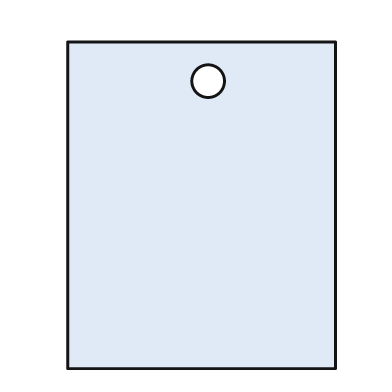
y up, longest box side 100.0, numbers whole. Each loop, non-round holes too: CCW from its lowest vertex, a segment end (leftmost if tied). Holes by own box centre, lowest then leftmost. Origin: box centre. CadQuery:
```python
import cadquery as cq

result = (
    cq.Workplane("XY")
    .moveTo(-41.0, -50.0)
    .lineTo(41.0, -50.0)
    .lineTo(41.0, 50.0)
    .lineTo(-41.0, 50.0)
    .close()
    .moveTo(2.0, 38.0)
    .circle(5.0)
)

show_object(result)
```